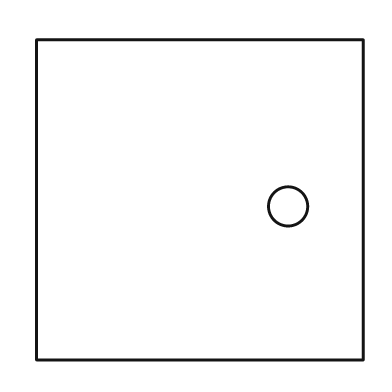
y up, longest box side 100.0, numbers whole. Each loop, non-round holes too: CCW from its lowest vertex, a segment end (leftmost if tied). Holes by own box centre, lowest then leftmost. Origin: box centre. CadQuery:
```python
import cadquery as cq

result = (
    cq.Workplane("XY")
    .moveTo(-50.0, -49.0)
    .lineTo(50.0, -49.0)
    .lineTo(50.0, 49.0)
    .lineTo(-50.0, 49.0)
    .close()
    .moveTo(27.0, -2.0)
    .circle(6.0)
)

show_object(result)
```